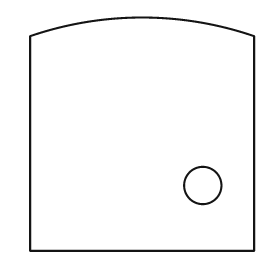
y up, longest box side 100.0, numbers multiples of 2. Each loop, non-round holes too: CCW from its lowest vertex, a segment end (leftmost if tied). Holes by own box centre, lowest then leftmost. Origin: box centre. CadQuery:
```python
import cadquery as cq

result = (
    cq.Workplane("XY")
    .moveTo(-48.0, -50.0)
    .lineTo(48.0, -50.0)
    .lineTo(48.0, 42.0)
    .threePointArc((0.0, 50.0), (-48.0, 42.0))
    .close()
    .moveTo(26.0, -22.0)
    .circle(8.0)
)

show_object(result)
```